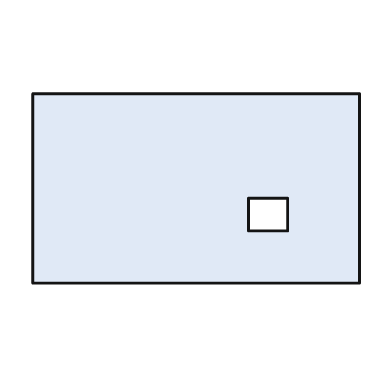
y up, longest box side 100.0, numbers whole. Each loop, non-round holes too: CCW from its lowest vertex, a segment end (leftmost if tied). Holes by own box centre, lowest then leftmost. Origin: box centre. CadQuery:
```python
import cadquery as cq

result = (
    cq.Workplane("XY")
    .moveTo(-50.0, -29.0)
    .lineTo(50.0, -29.0)
    .lineTo(50.0, 29.0)
    .lineTo(-50.0, 29.0)
    .close()
    .moveTo(16.0, -13.0)
    .lineTo(28.0, -13.0)
    .lineTo(28.0, -3.0)
    .lineTo(16.0, -3.0)
    .close()
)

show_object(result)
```